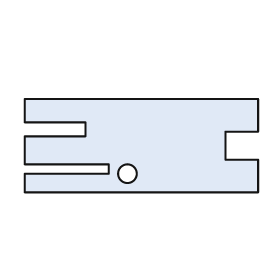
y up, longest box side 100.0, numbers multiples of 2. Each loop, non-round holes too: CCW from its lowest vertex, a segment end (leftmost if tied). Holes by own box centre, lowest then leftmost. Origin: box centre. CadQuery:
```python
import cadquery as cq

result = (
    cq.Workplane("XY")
    .moveTo(-50.0, -20.0)
    .lineTo(50.0, -20.0)
    .lineTo(50.0, -6.0)
    .lineTo(36.0, -6.0)
    .lineTo(36.0, 6.0)
    .lineTo(50.0, 6.0)
    .lineTo(50.0, 20.0)
    .lineTo(-50.0, 20.0)
    .lineTo(-50.0, 10.0)
    .lineTo(-24.0, 10.0)
    .lineTo(-24.0, 4.0)
    .lineTo(-50.0, 4.0)
    .lineTo(-50.0, -8.0)
    .lineTo(-14.0, -8.0)
    .lineTo(-14.0, -12.0)
    .lineTo(-50.0, -12.0)
    .close()
    .moveTo(-6.0, -12.0)
    .circle(4.0)
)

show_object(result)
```